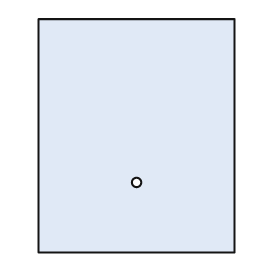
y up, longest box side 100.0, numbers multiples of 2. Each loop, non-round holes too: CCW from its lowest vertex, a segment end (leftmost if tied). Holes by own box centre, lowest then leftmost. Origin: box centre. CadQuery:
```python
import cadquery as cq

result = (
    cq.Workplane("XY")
    .moveTo(-42.0, -50.0)
    .lineTo(42.0, -50.0)
    .lineTo(42.0, 50.0)
    .lineTo(-42.0, 50.0)
    .close()
    .moveTo(0.0, -20.0)
    .circle(2.0)
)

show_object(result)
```